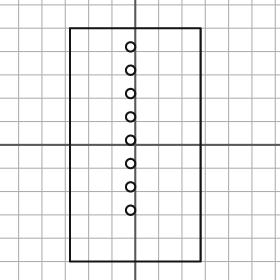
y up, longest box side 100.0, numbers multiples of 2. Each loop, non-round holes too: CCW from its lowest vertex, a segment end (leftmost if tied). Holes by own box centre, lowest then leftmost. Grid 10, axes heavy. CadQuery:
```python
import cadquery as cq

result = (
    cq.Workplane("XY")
    .moveTo(-28.0, -50.0)
    .lineTo(28.0, -50.0)
    .lineTo(28.0, 50.0)
    .lineTo(-28.0, 50.0)
    .close()
    .moveTo(-2.0, -28.0)
    .circle(2.0)
    .moveTo(-2.0, -18.0)
    .circle(2.0)
    .moveTo(-2.0, -8.0)
    .circle(2.0)
    .moveTo(-2.0, 2.0)
    .circle(2.0)
    .moveTo(-2.0, 12.0)
    .circle(2.0)
    .moveTo(-2.0, 22.0)
    .circle(2.0)
    .moveTo(-2.0, 32.0)
    .circle(2.0)
    .moveTo(-2.0, 42.0)
    .circle(2.0)
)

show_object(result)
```